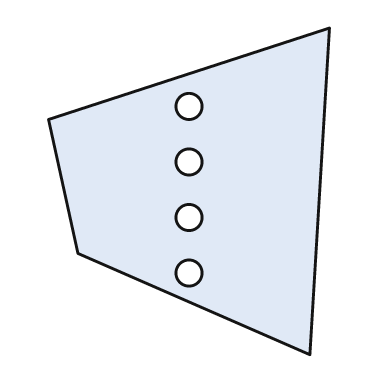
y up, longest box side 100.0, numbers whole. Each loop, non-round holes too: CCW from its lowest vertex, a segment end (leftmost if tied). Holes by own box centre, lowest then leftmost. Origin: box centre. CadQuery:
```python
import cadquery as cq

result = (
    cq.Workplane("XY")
    .moveTo(37.0, -50.0)
    .lineTo(43.0, 50.0)
    .lineTo(-43.0, 22.0)
    .lineTo(-34.0, -19.0)
    .close()
    .moveTo(0.0, -25.0)
    .circle(4.0)
    .moveTo(0.0, -8.0)
    .circle(4.0)
    .moveTo(0.0, 9.0)
    .circle(4.0)
    .moveTo(0.0, 26.0)
    .circle(4.0)
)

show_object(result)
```